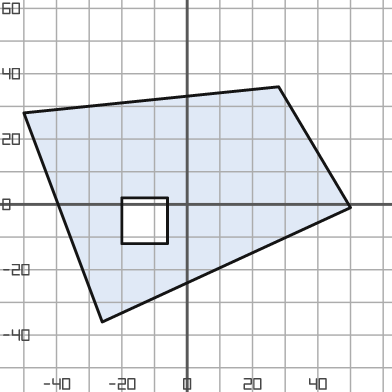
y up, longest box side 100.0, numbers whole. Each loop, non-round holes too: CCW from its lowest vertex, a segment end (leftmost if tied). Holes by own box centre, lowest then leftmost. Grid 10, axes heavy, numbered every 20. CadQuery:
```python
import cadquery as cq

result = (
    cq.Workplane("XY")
    .moveTo(-26.0, -36.0)
    .lineTo(50.0, -1.0)
    .lineTo(28.0, 36.0)
    .lineTo(-50.0, 28.0)
    .close()
    .moveTo(-20.0, -12.0)
    .lineTo(-6.0, -12.0)
    .lineTo(-6.0, 2.0)
    .lineTo(-20.0, 2.0)
    .close()
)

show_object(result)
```